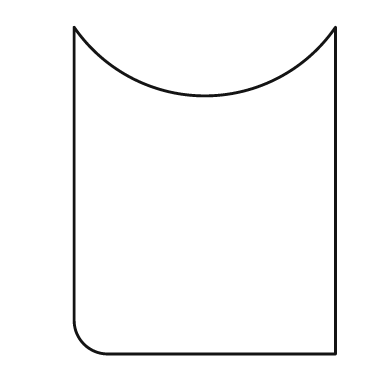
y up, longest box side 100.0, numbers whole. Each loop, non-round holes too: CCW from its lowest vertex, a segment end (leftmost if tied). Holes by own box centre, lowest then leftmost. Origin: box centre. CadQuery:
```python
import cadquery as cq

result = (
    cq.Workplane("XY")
    .moveTo(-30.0, -50.0)
    .lineTo(40.0, -50.0)
    .lineTo(40.0, 50.0)
    .threePointArc((0.0, 29.0), (-40.0, 50.0))
    .lineTo(-40.0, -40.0)
    .threePointArc((-37.0, -47.0), (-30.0, -50.0))
    .close()
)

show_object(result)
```